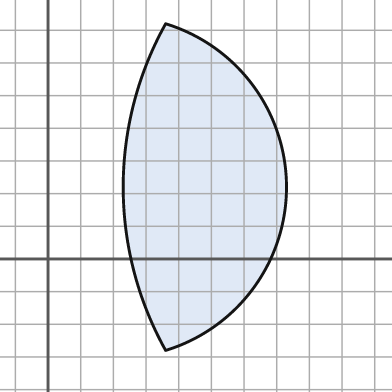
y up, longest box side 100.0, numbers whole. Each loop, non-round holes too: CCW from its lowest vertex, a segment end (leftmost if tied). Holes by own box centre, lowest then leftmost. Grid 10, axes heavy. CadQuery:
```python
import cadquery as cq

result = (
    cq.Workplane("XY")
    .moveTo(36.0, -28.0)
    .threePointArc((73.0, 22.0), (36.0, 72.0))
    .threePointArc((23.0, 22.0), (36.0, -28.0))
    .close()
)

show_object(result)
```